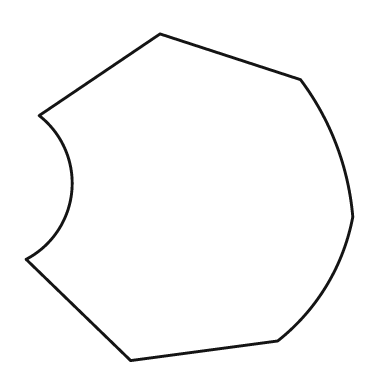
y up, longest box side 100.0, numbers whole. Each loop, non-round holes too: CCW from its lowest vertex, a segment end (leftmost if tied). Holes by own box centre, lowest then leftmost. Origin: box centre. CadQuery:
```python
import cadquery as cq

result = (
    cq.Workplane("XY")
    .moveTo(-18.0, -50.0)
    .lineTo(27.0, -44.0)
    .threePointArc((42.0, -27.0), (50.0, -6.0))
    .threePointArc((45.0, 16.0), (34.0, 36.0))
    .lineTo(-9.0, 50.0)
    .lineTo(-46.0, 25.0)
    .threePointArc((-36.0, 2.0), (-50.0, -19.0))
    .close()
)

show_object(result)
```